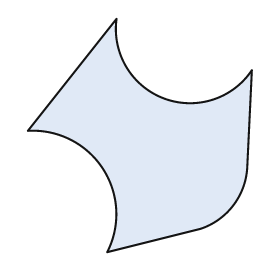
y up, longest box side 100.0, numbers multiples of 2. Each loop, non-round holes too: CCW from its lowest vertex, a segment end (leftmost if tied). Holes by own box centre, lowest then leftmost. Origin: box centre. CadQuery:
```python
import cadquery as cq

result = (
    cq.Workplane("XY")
    .moveTo(-14.0, -50.0)
    .lineTo(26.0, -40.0)
    .threePointArc((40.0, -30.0), (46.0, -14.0))
    .lineTo(48.0, 28.0)
    .threePointArc((10.0, 16.0), (-10.0, 50.0))
    .lineTo(-48.0, 2.0)
    .threePointArc((-16.0, -14.0), (-14.0, -50.0))
    .close()
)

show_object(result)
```